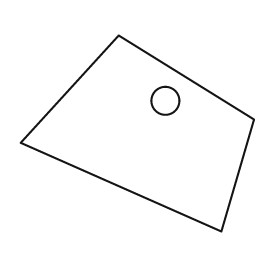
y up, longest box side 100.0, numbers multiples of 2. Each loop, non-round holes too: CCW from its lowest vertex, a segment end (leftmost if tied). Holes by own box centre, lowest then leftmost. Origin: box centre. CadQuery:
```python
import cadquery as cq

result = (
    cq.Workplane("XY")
    .moveTo(36.0, -42.0)
    .lineTo(50.0, 6.0)
    .lineTo(-8.0, 42.0)
    .lineTo(-50.0, -4.0)
    .close()
    .moveTo(12.0, 14.0)
    .circle(6.0)
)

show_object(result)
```